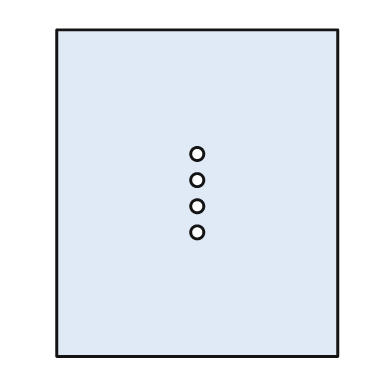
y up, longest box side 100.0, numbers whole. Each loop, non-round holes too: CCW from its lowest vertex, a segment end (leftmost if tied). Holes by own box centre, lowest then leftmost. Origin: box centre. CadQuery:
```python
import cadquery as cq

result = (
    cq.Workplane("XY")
    .moveTo(-43.0, -50.0)
    .lineTo(43.0, -50.0)
    .lineTo(43.0, 50.0)
    .lineTo(-43.0, 50.0)
    .close()
    .moveTo(0.0, -12.0)
    .circle(2.0)
    .moveTo(0.0, -4.0)
    .circle(2.0)
    .moveTo(0.0, 4.0)
    .circle(2.0)
    .moveTo(0.0, 12.0)
    .circle(2.0)
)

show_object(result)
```